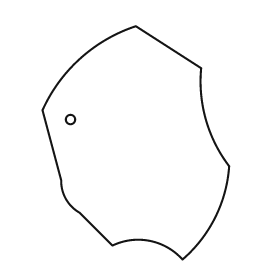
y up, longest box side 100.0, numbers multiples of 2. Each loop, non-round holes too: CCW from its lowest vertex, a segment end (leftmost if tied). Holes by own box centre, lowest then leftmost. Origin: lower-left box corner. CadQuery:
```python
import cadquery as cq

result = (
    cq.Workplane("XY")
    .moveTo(60.0, 0.0)
    .threePointArc((74.0, 18.0), (80.0, 40.0))
    .threePointArc((70.0, 60.0), (68.0, 82.0))
    .lineTo(40.0, 100.0)
    .threePointArc((16.0, 86.0), (0.0, 64.0))
    .lineTo(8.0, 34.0)
    .threePointArc((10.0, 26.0), (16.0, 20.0))
    .lineTo(30.0, 6.0)
    .threePointArc((46.0, 8.0), (60.0, 0.0))
    .close()
    .moveTo(12.0, 60.0)
    .circle(2.0)
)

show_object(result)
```